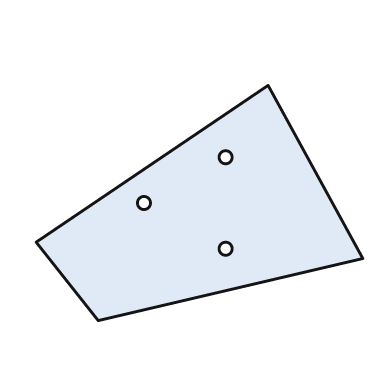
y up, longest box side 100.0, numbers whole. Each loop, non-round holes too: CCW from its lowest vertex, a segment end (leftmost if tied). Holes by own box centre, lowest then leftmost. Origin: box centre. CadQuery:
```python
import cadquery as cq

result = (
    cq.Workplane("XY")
    .moveTo(-31.0, -36.0)
    .lineTo(50.0, -17.0)
    .lineTo(21.0, 36.0)
    .lineTo(-50.0, -12.0)
    .close()
    .moveTo(8.0, -14.0)
    .circle(2.0)
    .moveTo(-17.0, 0.0)
    .circle(2.0)
    .moveTo(8.0, 14.0)
    .circle(2.0)
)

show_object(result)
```